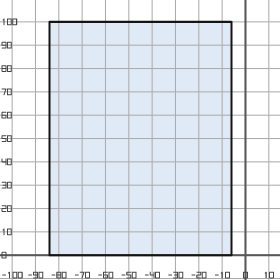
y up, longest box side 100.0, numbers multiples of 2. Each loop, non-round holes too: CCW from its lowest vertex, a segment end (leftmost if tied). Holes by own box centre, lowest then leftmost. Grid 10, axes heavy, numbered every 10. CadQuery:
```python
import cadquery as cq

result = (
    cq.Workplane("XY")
    .moveTo(-84.0, 0.0)
    .lineTo(-6.0, 0.0)
    .lineTo(-6.0, 100.0)
    .lineTo(-84.0, 100.0)
    .close()
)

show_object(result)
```